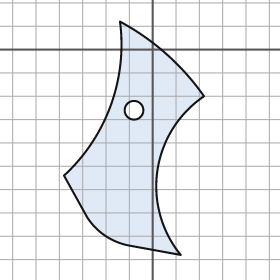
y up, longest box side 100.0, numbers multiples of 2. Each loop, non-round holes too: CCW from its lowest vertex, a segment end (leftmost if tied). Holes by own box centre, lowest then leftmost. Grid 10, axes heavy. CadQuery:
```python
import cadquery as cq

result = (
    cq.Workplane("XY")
    .moveTo(12.0, -88.0)
    .threePointArc((2.0, -52.0), (22.0, -20.0))
    .threePointArc((6.0, -2.0), (-14.0, 12.0))
    .threePointArc((-18.0, -24.0), (-38.0, -54.0))
    .lineTo(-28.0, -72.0)
    .threePointArc((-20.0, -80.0), (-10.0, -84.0))
    .close()
    .moveTo(-8.0, -26.0)
    .circle(4.0)
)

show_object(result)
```